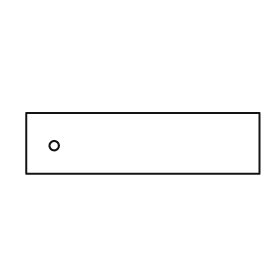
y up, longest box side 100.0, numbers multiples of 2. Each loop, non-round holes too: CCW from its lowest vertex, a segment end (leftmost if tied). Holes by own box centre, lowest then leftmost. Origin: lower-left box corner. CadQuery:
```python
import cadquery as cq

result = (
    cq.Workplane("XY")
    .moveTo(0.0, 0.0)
    .lineTo(100.0, 0.0)
    .lineTo(100.0, 26.0)
    .lineTo(0.0, 26.0)
    .close()
    .moveTo(12.0, 12.0)
    .circle(2.0)
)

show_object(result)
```